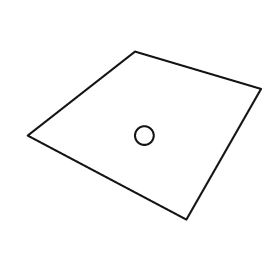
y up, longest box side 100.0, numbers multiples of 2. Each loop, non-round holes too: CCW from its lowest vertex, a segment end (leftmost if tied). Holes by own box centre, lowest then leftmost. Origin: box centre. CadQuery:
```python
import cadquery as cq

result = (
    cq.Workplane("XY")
    .moveTo(18.0, -36.0)
    .lineTo(50.0, 20.0)
    .lineTo(-4.0, 36.0)
    .lineTo(-50.0, 0.0)
    .close()
    .moveTo(0.0, 0.0)
    .circle(4.0)
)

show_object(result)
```